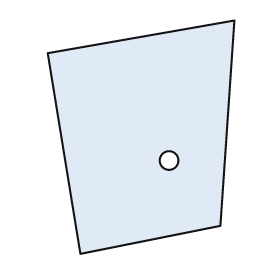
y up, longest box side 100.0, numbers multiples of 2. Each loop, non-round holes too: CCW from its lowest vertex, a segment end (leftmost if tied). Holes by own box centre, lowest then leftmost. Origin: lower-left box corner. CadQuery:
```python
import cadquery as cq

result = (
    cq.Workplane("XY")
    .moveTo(14.0, 0.0)
    .lineTo(74.0, 12.0)
    .lineTo(80.0, 100.0)
    .lineTo(0.0, 86.0)
    .close()
    .moveTo(52.0, 40.0)
    .circle(4.0)
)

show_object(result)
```